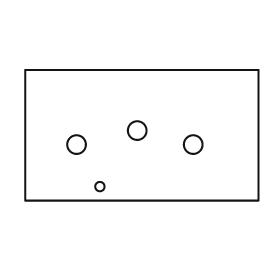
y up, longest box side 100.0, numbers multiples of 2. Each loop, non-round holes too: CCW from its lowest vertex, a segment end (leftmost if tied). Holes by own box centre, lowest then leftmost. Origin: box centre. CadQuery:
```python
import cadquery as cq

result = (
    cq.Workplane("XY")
    .moveTo(-50.0, -28.0)
    .lineTo(50.0, -28.0)
    .lineTo(50.0, 28.0)
    .lineTo(-50.0, 28.0)
    .close()
    .moveTo(-18.0, -22.0)
    .circle(2.0)
    .moveTo(-28.0, -4.0)
    .circle(4.0)
    .moveTo(22.0, -4.0)
    .circle(4.0)
    .moveTo(-2.0, 2.0)
    .circle(4.0)
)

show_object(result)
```